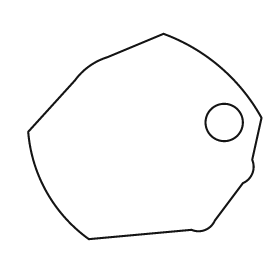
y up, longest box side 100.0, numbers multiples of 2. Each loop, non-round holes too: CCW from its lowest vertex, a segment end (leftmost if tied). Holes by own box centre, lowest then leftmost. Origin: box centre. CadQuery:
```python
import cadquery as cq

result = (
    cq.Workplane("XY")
    .moveTo(-24.0, -44.0)
    .lineTo(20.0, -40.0)
    .threePointArc((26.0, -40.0), (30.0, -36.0))
    .lineTo(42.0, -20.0)
    .threePointArc((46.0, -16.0), (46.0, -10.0))
    .lineTo(50.0, 8.0)
    .threePointArc((32.0, 30.0), (8.0, 44.0))
    .lineTo(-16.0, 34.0)
    .threePointArc((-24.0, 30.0), (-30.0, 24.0))
    .lineTo(-50.0, 2.0)
    .threePointArc((-42.0, -24.0), (-24.0, -44.0))
    .close()
    .moveTo(34.0, 6.0)
    .circle(8.0)
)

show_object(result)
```